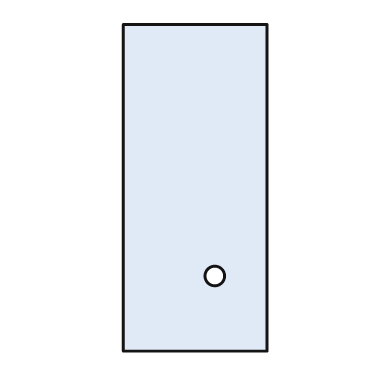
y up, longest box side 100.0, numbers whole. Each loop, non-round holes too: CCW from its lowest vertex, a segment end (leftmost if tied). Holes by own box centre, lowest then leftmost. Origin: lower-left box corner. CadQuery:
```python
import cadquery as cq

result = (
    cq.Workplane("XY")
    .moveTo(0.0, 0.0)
    .lineTo(44.0, 0.0)
    .lineTo(44.0, 100.0)
    .lineTo(0.0, 100.0)
    .close()
    .moveTo(28.0, 23.0)
    .circle(3.0)
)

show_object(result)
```